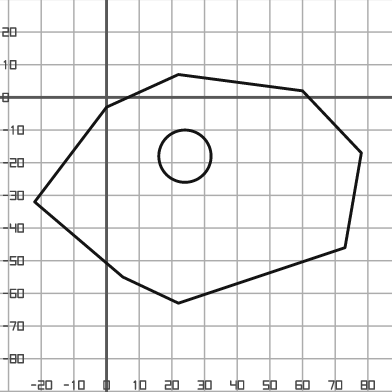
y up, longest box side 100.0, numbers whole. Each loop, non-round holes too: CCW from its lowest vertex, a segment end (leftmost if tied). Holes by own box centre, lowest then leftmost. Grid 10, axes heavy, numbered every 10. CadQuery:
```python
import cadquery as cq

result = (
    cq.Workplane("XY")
    .moveTo(22.0, -63.0)
    .lineTo(73.0, -46.0)
    .lineTo(78.0, -17.0)
    .lineTo(60.0, 2.0)
    .lineTo(22.0, 7.0)
    .lineTo(0.0, -3.0)
    .lineTo(-22.0, -32.0)
    .lineTo(5.0, -55.0)
    .close()
    .moveTo(24.0, -18.0)
    .circle(8.0)
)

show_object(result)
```